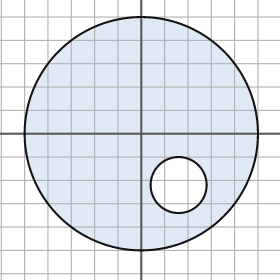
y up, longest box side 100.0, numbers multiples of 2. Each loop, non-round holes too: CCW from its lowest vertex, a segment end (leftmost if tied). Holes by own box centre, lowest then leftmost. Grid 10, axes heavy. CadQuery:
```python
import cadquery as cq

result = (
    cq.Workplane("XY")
    .moveTo(0.0, 0.0)
    .circle(50.0)
    .moveTo(16.0, -22.0)
    .circle(12.0)
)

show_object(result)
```